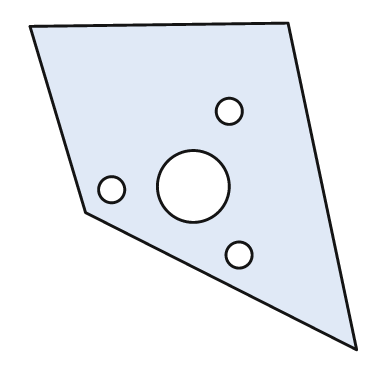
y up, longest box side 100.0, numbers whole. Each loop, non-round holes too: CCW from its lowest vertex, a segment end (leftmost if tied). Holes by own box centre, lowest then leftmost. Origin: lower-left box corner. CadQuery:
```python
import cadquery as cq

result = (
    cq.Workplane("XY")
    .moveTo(100.0, 0.0)
    .lineTo(79.0, 100.0)
    .lineTo(0.0, 99.0)
    .lineTo(17.0, 42.0)
    .close()
    .moveTo(64.0, 29.0)
    .circle(4.0)
    .moveTo(25.0, 49.0)
    .circle(4.0)
    .moveTo(50.0, 50.0)
    .circle(11.0)
    .moveTo(61.0, 73.0)
    .circle(4.0)
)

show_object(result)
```